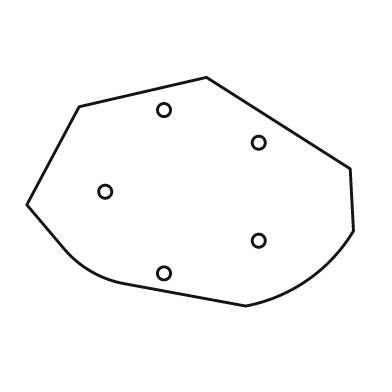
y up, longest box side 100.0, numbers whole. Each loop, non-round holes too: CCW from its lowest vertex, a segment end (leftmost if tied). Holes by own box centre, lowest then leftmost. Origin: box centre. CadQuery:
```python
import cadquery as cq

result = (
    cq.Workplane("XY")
    .moveTo(17.0, -35.0)
    .threePointArc((36.0, -27.0), (50.0, -12.0))
    .lineTo(49.0, 7.0)
    .lineTo(5.0, 35.0)
    .lineTo(-34.0, 26.0)
    .lineTo(-50.0, -4.0)
    .lineTo(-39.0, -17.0)
    .threePointArc((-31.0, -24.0), (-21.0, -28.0))
    .close()
    .moveTo(-8.0, -25.0)
    .circle(2.0)
    .moveTo(21.0, -15.0)
    .circle(2.0)
    .moveTo(-26.0, 0.0)
    .circle(2.0)
    .moveTo(21.0, 15.0)
    .circle(2.0)
    .moveTo(-8.0, 25.0)
    .circle(2.0)
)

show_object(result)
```